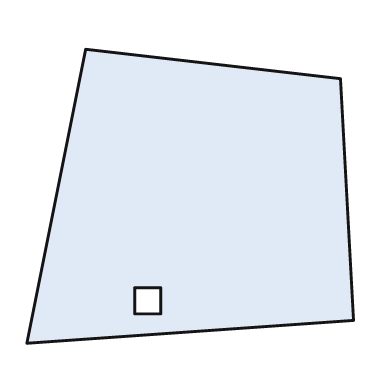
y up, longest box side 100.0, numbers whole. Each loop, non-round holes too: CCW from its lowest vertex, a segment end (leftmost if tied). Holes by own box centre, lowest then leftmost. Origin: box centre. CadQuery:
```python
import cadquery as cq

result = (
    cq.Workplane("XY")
    .moveTo(-50.0, -45.0)
    .lineTo(50.0, -38.0)
    .lineTo(46.0, 36.0)
    .lineTo(-32.0, 45.0)
    .close()
    .moveTo(-17.0, -36.0)
    .lineTo(-9.0, -36.0)
    .lineTo(-9.0, -28.0)
    .lineTo(-17.0, -28.0)
    .close()
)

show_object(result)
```